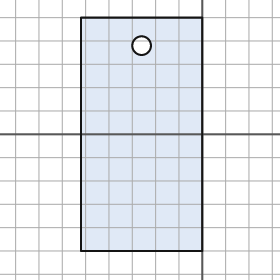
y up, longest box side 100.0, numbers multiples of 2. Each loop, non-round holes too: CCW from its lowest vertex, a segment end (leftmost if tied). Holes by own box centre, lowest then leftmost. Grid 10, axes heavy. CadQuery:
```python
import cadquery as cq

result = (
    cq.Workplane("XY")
    .moveTo(-52.0, -50.0)
    .lineTo(0.0, -50.0)
    .lineTo(0.0, 50.0)
    .lineTo(-52.0, 50.0)
    .close()
    .moveTo(-26.0, 38.0)
    .circle(4.0)
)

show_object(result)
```